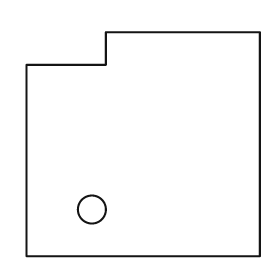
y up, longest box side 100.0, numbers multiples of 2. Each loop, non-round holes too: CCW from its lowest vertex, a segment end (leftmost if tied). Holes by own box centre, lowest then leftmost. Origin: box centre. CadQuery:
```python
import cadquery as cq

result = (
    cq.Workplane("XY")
    .moveTo(-50.0, -48.0)
    .lineTo(50.0, -48.0)
    .lineTo(50.0, 48.0)
    .lineTo(-16.0, 48.0)
    .lineTo(-16.0, 34.0)
    .lineTo(-50.0, 34.0)
    .close()
    .moveTo(-22.0, -28.0)
    .circle(6.0)
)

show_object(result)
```